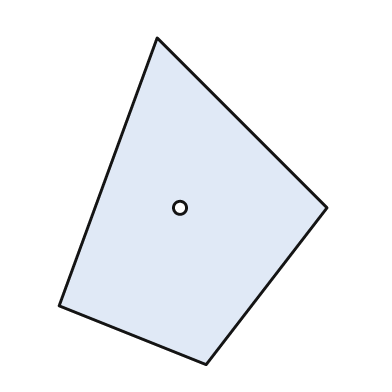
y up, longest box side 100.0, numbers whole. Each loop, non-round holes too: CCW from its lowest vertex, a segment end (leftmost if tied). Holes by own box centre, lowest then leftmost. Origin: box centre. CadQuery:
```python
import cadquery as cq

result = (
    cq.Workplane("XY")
    .moveTo(4.0, -50.0)
    .lineTo(41.0, -2.0)
    .lineTo(-11.0, 50.0)
    .lineTo(-41.0, -32.0)
    .close()
    .moveTo(-4.0, -2.0)
    .circle(2.0)
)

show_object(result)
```